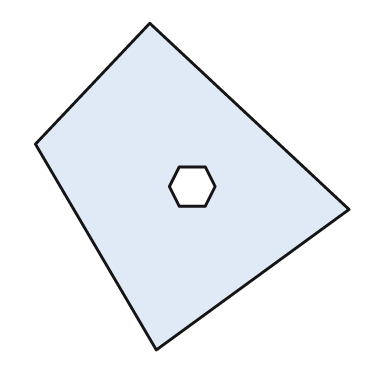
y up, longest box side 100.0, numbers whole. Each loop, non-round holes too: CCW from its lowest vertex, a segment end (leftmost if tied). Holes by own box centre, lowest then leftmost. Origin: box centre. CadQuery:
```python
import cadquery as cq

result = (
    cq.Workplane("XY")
    .moveTo(-11.0, -50.0)
    .lineTo(48.0, -7.0)
    .lineTo(-13.0, 50.0)
    .lineTo(-48.0, 13.0)
    .close()
    .moveTo(-4.0, -6.0)
    .lineTo(4.0, -6.0)
    .lineTo(7.0, 0.0)
    .lineTo(4.0, 6.0)
    .lineTo(-4.0, 6.0)
    .lineTo(-7.0, 0.0)
    .close()
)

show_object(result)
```